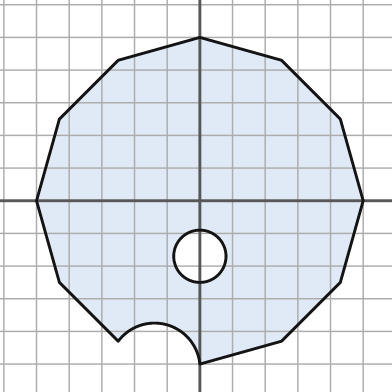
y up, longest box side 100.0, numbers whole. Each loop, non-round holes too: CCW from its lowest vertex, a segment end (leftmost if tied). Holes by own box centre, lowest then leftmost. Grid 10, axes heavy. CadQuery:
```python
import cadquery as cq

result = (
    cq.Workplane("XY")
    .moveTo(0.0, -50.0)
    .lineTo(25.0, -43.0)
    .lineTo(43.0, -25.0)
    .lineTo(50.0, 0.0)
    .lineTo(43.0, 25.0)
    .lineTo(25.0, 43.0)
    .lineTo(0.0, 50.0)
    .lineTo(-25.0, 43.0)
    .lineTo(-43.0, 25.0)
    .lineTo(-50.0, 0.0)
    .lineTo(-43.0, -25.0)
    .lineTo(-25.0, -43.0)
    .threePointArc((-10.0, -38.0), (0.0, -50.0))
    .close()
    .moveTo(0.0, -17.0)
    .circle(8.0)
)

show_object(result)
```